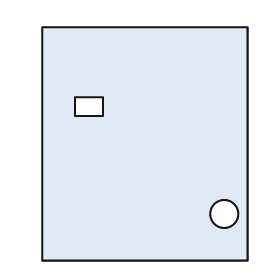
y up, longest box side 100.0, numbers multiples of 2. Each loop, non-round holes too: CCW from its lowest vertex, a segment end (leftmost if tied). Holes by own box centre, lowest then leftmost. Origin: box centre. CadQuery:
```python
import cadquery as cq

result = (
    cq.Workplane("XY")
    .moveTo(-44.0, -50.0)
    .lineTo(44.0, -50.0)
    .lineTo(44.0, 50.0)
    .lineTo(-44.0, 50.0)
    .close()
    .moveTo(34.0, -30.0)
    .circle(6.0)
    .moveTo(-30.0, 12.0)
    .lineTo(-18.0, 12.0)
    .lineTo(-18.0, 20.0)
    .lineTo(-30.0, 20.0)
    .close()
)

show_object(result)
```